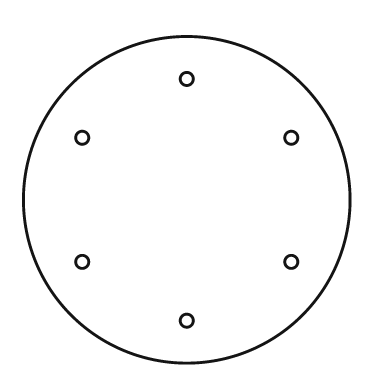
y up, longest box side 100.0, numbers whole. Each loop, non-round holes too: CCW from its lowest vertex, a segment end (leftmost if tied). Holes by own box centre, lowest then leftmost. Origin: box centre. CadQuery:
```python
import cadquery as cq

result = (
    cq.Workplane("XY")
    .moveTo(0.0, 0.0)
    .circle(50.0)
    .moveTo(0.0, -37.0)
    .circle(2.0)
    .moveTo(-32.0, -19.0)
    .circle(2.0)
    .moveTo(32.0, -19.0)
    .circle(2.0)
    .moveTo(-32.0, 19.0)
    .circle(2.0)
    .moveTo(32.0, 19.0)
    .circle(2.0)
    .moveTo(0.0, 37.0)
    .circle(2.0)
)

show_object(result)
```